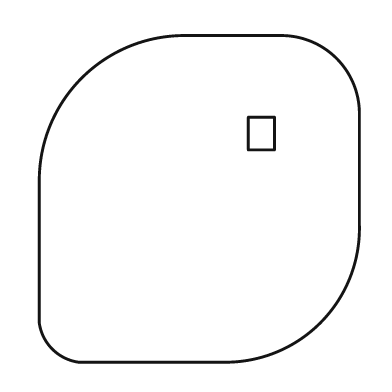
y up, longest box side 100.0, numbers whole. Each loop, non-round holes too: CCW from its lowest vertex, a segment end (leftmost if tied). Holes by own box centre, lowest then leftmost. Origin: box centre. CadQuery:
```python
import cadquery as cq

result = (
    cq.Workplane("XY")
    .moveTo(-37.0, -50.0)
    .lineTo(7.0, -50.0)
    .threePointArc((37.0, -38.0), (49.0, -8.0))
    .lineTo(49.0, 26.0)
    .threePointArc((42.0, 43.0), (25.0, 50.0))
    .lineTo(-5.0, 50.0)
    .threePointArc((-36.0, 37.0), (-49.0, 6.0))
    .lineTo(-49.0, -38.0)
    .threePointArc((-45.0, -46.0), (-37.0, -50.0))
    .close()
    .moveTo(15.0, 15.0)
    .lineTo(23.0, 15.0)
    .lineTo(23.0, 25.0)
    .lineTo(15.0, 25.0)
    .close()
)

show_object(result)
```